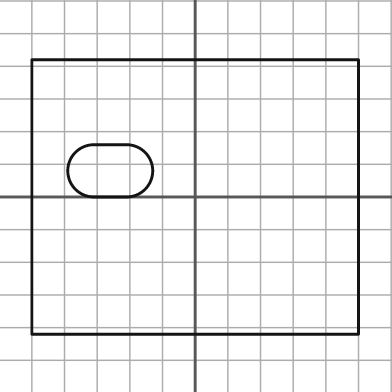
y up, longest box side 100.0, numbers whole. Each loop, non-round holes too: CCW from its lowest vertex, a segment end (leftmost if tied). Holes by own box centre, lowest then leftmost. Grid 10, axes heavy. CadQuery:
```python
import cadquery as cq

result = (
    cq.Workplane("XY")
    .moveTo(-50.0, -42.0)
    .lineTo(50.0, -42.0)
    .lineTo(50.0, 42.0)
    .lineTo(-50.0, 42.0)
    .close()
    .moveTo(-31.0, 0.0)
    .lineTo(-21.0, 0.0)
    .threePointArc((-13.0, 8.0), (-21.0, 16.0))
    .lineTo(-31.0, 16.0)
    .threePointArc((-39.0, 8.0), (-31.0, 0.0))
    .close()
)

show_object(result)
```